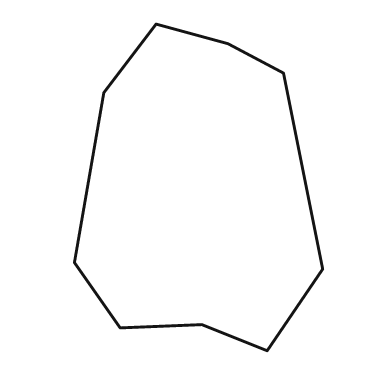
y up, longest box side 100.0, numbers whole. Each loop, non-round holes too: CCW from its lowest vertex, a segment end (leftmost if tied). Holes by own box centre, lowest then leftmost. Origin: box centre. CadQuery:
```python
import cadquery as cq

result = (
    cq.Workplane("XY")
    .moveTo(21.0, -50.0)
    .lineTo(38.0, -25.0)
    .lineTo(26.0, 35.0)
    .lineTo(9.0, 44.0)
    .lineTo(-13.0, 50.0)
    .lineTo(-29.0, 29.0)
    .lineTo(-38.0, -23.0)
    .lineTo(-24.0, -43.0)
    .lineTo(1.0, -42.0)
    .close()
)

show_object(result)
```